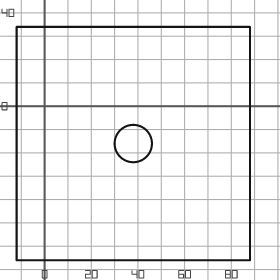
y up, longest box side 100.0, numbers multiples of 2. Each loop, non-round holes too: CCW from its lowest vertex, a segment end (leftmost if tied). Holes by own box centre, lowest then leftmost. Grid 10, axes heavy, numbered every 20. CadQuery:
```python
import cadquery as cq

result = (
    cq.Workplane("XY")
    .moveTo(-12.0, -66.0)
    .lineTo(88.0, -66.0)
    .lineTo(88.0, 34.0)
    .lineTo(-12.0, 34.0)
    .close()
    .moveTo(38.0, -16.0)
    .circle(8.0)
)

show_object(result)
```